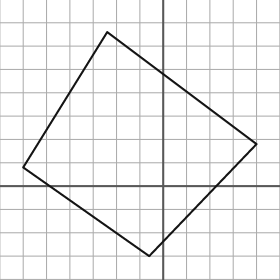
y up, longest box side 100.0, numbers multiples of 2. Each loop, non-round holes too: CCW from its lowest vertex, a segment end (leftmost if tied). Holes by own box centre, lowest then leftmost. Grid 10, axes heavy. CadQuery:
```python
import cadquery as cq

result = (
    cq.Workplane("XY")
    .moveTo(-6.0, -30.0)
    .lineTo(40.0, 18.0)
    .lineTo(-24.0, 66.0)
    .lineTo(-60.0, 8.0)
    .close()
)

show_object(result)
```